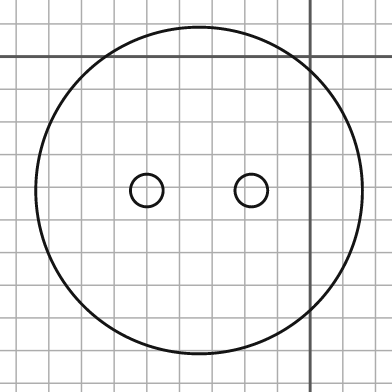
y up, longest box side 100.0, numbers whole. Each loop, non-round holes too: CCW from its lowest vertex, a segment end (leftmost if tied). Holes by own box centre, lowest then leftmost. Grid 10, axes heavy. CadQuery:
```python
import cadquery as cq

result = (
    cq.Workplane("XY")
    .moveTo(-34.0, -41.0)
    .circle(50.0)
    .moveTo(-50.0, -41.0)
    .circle(5.0)
    .moveTo(-18.0, -41.0)
    .circle(5.0)
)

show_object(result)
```